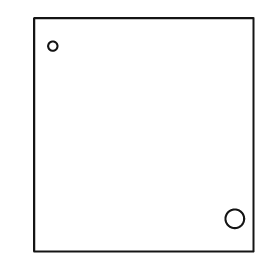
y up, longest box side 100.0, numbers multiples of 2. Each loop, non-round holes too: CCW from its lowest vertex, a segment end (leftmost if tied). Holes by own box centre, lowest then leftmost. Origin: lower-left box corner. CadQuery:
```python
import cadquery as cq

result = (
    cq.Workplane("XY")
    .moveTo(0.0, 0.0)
    .lineTo(94.0, 0.0)
    .lineTo(94.0, 100.0)
    .lineTo(0.0, 100.0)
    .close()
    .moveTo(86.0, 14.0)
    .circle(4.0)
    .moveTo(8.0, 88.0)
    .circle(2.0)
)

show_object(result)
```